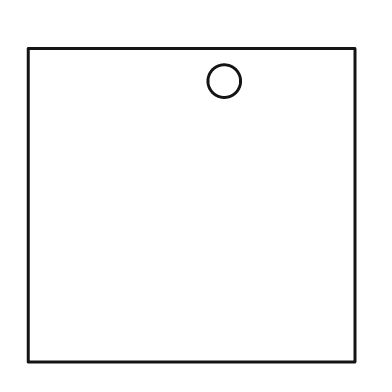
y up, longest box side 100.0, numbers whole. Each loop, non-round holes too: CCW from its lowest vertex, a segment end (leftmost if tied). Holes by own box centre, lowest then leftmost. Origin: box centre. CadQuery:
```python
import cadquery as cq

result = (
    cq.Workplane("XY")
    .moveTo(-50.0, -48.0)
    .lineTo(50.0, -48.0)
    .lineTo(50.0, 48.0)
    .lineTo(-50.0, 48.0)
    .close()
    .moveTo(10.0, 38.0)
    .circle(5.0)
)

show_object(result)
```